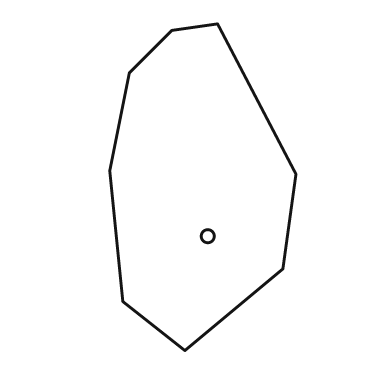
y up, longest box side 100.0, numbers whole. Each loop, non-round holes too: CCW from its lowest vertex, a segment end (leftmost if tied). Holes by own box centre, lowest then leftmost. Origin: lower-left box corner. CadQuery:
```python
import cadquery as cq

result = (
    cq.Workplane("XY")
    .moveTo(23.0, 0.0)
    .lineTo(53.0, 25.0)
    .lineTo(57.0, 54.0)
    .lineTo(33.0, 100.0)
    .lineTo(19.0, 98.0)
    .lineTo(6.0, 85.0)
    .lineTo(0.0, 55.0)
    .lineTo(4.0, 15.0)
    .close()
    .moveTo(30.0, 35.0)
    .circle(2.0)
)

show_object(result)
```